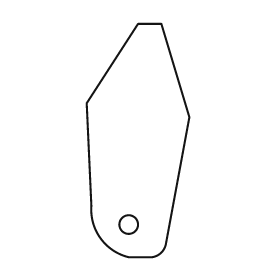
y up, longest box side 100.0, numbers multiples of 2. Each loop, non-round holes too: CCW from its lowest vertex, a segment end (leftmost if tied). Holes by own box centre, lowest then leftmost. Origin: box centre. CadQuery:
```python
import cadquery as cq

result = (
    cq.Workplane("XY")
    .moveTo(-4.0, -50.0)
    .lineTo(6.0, -50.0)
    .threePointArc((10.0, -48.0), (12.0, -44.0))
    .lineTo(22.0, 10.0)
    .lineTo(10.0, 50.0)
    .lineTo(0.0, 50.0)
    .lineTo(-22.0, 16.0)
    .lineTo(-20.0, -28.0)
    .threePointArc((-16.0, -42.0), (-4.0, -50.0))
    .close()
    .moveTo(-4.0, -36.0)
    .circle(4.0)
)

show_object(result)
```